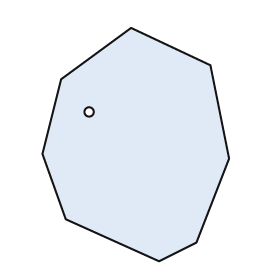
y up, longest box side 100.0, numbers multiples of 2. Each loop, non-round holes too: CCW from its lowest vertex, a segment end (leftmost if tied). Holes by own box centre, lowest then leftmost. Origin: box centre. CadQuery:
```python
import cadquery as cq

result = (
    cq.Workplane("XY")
    .moveTo(10.0, -50.0)
    .lineTo(26.0, -42.0)
    .lineTo(40.0, -6.0)
    .lineTo(32.0, 34.0)
    .lineTo(-2.0, 50.0)
    .lineTo(-32.0, 28.0)
    .lineTo(-40.0, -4.0)
    .lineTo(-30.0, -32.0)
    .close()
    .moveTo(-20.0, 14.0)
    .circle(2.0)
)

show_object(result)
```